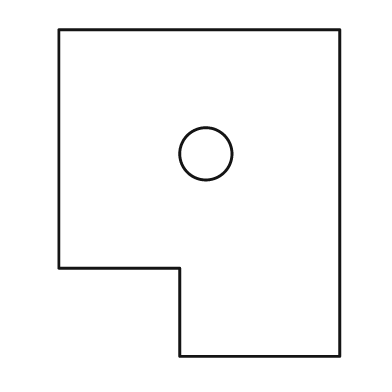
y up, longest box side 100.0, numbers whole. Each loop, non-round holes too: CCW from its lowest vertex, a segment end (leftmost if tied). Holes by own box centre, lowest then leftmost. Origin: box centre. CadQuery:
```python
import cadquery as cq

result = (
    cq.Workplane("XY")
    .moveTo(-6.0, -50.0)
    .lineTo(43.0, -50.0)
    .lineTo(43.0, 50.0)
    .lineTo(-43.0, 50.0)
    .lineTo(-43.0, -23.0)
    .lineTo(-6.0, -23.0)
    .close()
    .moveTo(2.0, 12.0)
    .circle(8.0)
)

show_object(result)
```